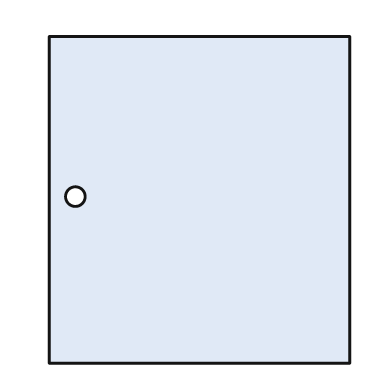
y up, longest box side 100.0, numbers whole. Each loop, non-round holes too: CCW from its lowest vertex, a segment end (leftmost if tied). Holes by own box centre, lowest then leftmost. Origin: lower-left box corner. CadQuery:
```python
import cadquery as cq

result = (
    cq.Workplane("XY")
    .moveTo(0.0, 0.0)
    .lineTo(92.0, 0.0)
    .lineTo(92.0, 100.0)
    .lineTo(0.0, 100.0)
    .close()
    .moveTo(8.0, 51.0)
    .circle(3.0)
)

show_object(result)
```